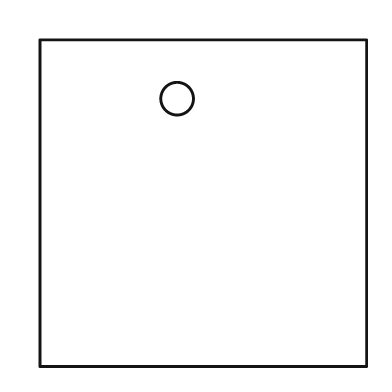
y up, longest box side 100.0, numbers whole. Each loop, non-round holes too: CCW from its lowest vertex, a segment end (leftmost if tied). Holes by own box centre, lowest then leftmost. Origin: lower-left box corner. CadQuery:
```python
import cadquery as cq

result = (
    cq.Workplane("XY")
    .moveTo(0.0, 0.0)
    .lineTo(100.0, 0.0)
    .lineTo(100.0, 100.0)
    .lineTo(0.0, 100.0)
    .close()
    .moveTo(42.0, 82.0)
    .circle(5.0)
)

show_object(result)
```